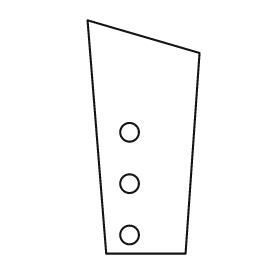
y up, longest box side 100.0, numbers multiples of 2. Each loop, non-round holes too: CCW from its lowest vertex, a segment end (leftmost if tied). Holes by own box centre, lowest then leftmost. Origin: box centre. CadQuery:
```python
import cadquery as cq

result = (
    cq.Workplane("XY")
    .moveTo(-16.0, -50.0)
    .lineTo(18.0, -50.0)
    .lineTo(24.0, 36.0)
    .lineTo(-24.0, 50.0)
    .close()
    .moveTo(-6.0, -42.0)
    .circle(4.0)
    .moveTo(-6.0, -20.0)
    .circle(4.0)
    .moveTo(-6.0, 2.0)
    .circle(4.0)
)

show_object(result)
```